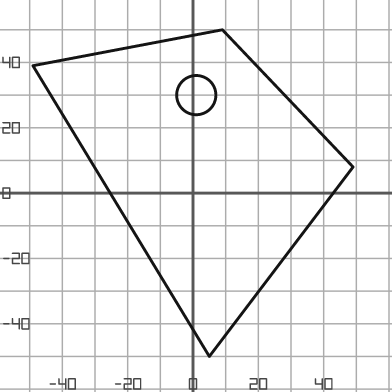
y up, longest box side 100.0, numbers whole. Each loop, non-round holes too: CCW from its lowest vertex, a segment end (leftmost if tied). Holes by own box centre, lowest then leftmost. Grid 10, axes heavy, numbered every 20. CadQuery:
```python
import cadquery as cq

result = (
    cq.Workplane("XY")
    .moveTo(5.0, -50.0)
    .lineTo(49.0, 8.0)
    .lineTo(9.0, 50.0)
    .lineTo(-49.0, 39.0)
    .close()
    .moveTo(1.0, 30.0)
    .circle(6.0)
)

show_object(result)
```